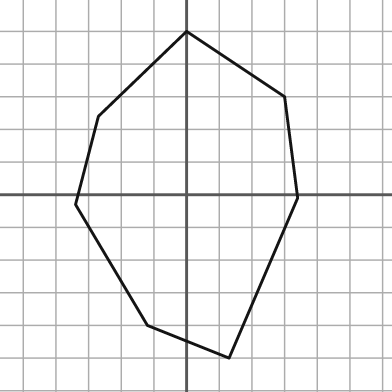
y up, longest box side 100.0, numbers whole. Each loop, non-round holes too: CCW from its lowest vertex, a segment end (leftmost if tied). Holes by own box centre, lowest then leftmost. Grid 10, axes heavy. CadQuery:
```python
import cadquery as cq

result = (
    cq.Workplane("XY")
    .moveTo(13.0, -50.0)
    .lineTo(34.0, -1.0)
    .lineTo(30.0, 30.0)
    .lineTo(0.0, 50.0)
    .lineTo(-27.0, 24.0)
    .lineTo(-34.0, -3.0)
    .lineTo(-12.0, -40.0)
    .close()
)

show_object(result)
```